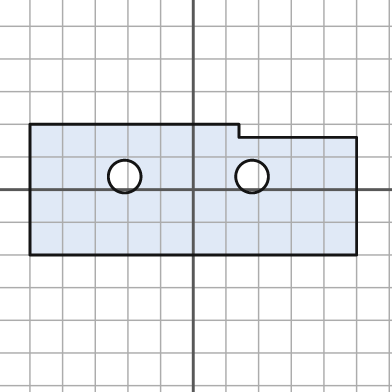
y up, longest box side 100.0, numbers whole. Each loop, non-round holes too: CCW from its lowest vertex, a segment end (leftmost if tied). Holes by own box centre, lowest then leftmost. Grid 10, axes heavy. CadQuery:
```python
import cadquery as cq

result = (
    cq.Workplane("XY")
    .moveTo(-50.0, -20.0)
    .lineTo(50.0, -20.0)
    .lineTo(50.0, 16.0)
    .lineTo(14.0, 16.0)
    .lineTo(14.0, 20.0)
    .lineTo(-50.0, 20.0)
    .close()
    .moveTo(-21.0, 4.0)
    .circle(5.0)
    .moveTo(18.0, 4.0)
    .circle(5.0)
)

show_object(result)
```